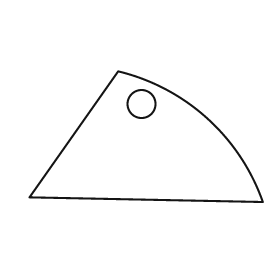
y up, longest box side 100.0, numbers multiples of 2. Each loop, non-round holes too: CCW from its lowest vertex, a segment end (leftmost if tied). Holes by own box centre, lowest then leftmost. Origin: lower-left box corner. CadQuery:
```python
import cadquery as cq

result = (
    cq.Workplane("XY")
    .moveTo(100.0, 0.0)
    .threePointArc((76.0, 36.0), (38.0, 56.0))
    .lineTo(0.0, 2.0)
    .close()
    .moveTo(48.0, 42.0)
    .circle(6.0)
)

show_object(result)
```